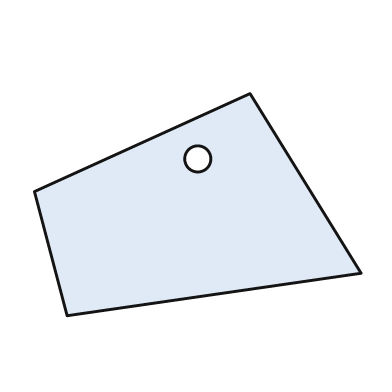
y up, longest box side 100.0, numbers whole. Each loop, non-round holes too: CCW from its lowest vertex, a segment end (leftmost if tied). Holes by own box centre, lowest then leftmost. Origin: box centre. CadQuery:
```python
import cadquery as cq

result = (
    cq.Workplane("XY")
    .moveTo(-40.0, -34.0)
    .lineTo(50.0, -21.0)
    .lineTo(16.0, 34.0)
    .lineTo(-50.0, 4.0)
    .close()
    .moveTo(0.0, 14.0)
    .circle(4.0)
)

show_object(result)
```